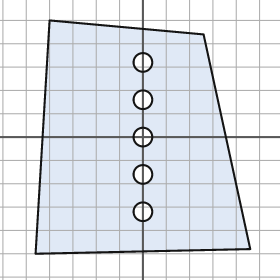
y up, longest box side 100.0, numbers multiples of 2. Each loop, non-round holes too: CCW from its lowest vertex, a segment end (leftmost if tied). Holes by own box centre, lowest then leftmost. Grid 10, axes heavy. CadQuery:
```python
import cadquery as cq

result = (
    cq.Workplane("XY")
    .moveTo(-46.0, -50.0)
    .lineTo(46.0, -48.0)
    .lineTo(26.0, 44.0)
    .lineTo(-40.0, 50.0)
    .close()
    .moveTo(0.0, -32.0)
    .circle(4.0)
    .moveTo(0.0, -16.0)
    .circle(4.0)
    .moveTo(0.0, 0.0)
    .circle(4.0)
    .moveTo(0.0, 16.0)
    .circle(4.0)
    .moveTo(0.0, 32.0)
    .circle(4.0)
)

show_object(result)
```